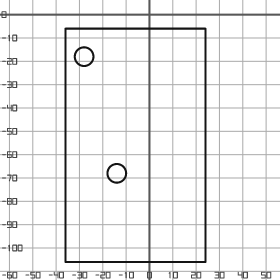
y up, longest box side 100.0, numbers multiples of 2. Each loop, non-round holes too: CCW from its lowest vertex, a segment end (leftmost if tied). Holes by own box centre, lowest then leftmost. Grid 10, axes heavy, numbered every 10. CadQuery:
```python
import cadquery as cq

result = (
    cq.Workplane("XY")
    .moveTo(-36.0, -106.0)
    .lineTo(24.0, -106.0)
    .lineTo(24.0, -6.0)
    .lineTo(-36.0, -6.0)
    .close()
    .moveTo(-14.0, -68.0)
    .circle(4.0)
    .moveTo(-28.0, -18.0)
    .circle(4.0)
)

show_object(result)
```